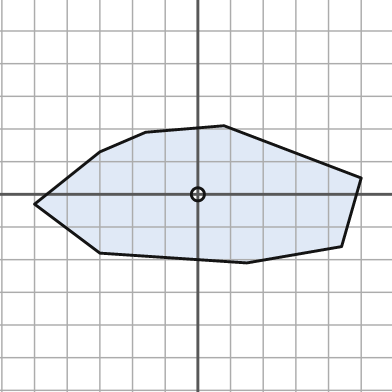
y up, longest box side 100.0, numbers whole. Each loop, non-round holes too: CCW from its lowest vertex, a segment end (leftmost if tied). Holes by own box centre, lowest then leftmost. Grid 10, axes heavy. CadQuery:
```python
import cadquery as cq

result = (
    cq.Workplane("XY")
    .moveTo(15.0, -21.0)
    .lineTo(44.0, -16.0)
    .lineTo(50.0, 5.0)
    .lineTo(8.0, 21.0)
    .lineTo(-16.0, 19.0)
    .lineTo(-30.0, 13.0)
    .lineTo(-50.0, -3.0)
    .lineTo(-30.0, -18.0)
    .close()
    .moveTo(0.0, 0.0)
    .circle(2.0)
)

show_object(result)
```